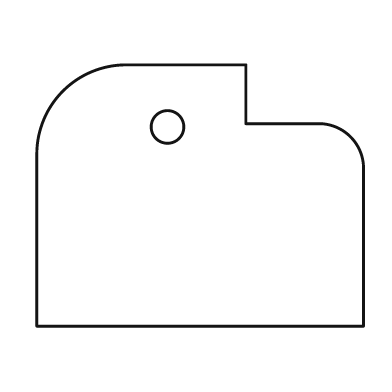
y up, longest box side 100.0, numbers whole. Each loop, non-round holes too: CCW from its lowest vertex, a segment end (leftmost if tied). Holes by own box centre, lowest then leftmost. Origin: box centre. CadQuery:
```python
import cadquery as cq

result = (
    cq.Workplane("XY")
    .moveTo(-50.0, -40.0)
    .lineTo(50.0, -40.0)
    .lineTo(50.0, 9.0)
    .threePointArc((46.0, 18.0), (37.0, 22.0))
    .lineTo(14.0, 22.0)
    .lineTo(14.0, 40.0)
    .lineTo(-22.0, 40.0)
    .threePointArc((-42.0, 32.0), (-50.0, 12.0))
    .close()
    .moveTo(-10.0, 21.0)
    .circle(5.0)
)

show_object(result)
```